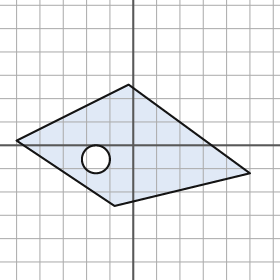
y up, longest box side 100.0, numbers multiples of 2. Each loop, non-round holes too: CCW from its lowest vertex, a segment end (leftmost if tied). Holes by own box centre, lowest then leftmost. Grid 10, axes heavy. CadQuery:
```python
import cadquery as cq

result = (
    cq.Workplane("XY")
    .moveTo(-8.0, -26.0)
    .lineTo(50.0, -12.0)
    .lineTo(-2.0, 26.0)
    .lineTo(-50.0, 2.0)
    .close()
    .moveTo(-16.0, -6.0)
    .circle(6.0)
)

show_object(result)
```